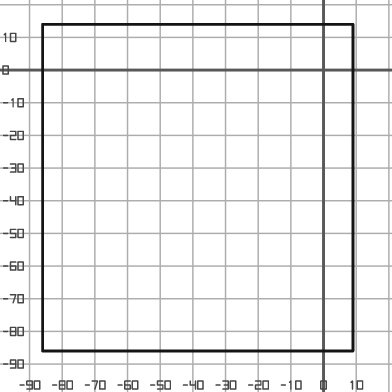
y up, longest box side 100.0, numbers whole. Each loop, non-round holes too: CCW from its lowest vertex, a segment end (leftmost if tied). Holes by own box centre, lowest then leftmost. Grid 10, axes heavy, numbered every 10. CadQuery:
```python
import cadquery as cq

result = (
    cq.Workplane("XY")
    .moveTo(-86.0, -86.0)
    .lineTo(9.0, -86.0)
    .lineTo(9.0, 14.0)
    .lineTo(-86.0, 14.0)
    .close()
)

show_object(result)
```